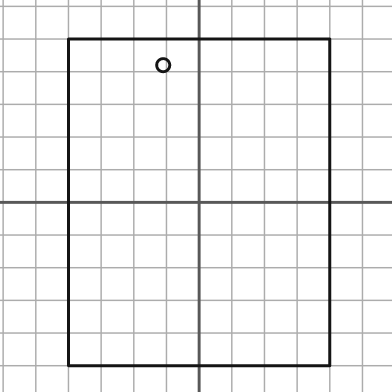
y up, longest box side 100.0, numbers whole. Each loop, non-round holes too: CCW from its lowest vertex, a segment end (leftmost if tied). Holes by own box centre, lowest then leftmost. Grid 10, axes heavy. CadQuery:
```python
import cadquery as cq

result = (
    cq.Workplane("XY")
    .moveTo(-40.0, -50.0)
    .lineTo(40.0, -50.0)
    .lineTo(40.0, 50.0)
    .lineTo(-40.0, 50.0)
    .close()
    .moveTo(-11.0, 42.0)
    .circle(2.0)
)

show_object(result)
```